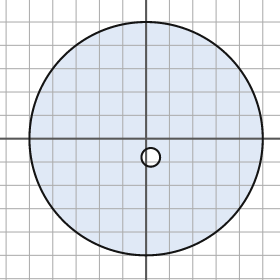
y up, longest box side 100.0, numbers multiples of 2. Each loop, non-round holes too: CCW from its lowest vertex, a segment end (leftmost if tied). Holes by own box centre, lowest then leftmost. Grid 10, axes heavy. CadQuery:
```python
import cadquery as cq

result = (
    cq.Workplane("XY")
    .moveTo(0.0, 0.0)
    .circle(50.0)
    .moveTo(2.0, -8.0)
    .circle(4.0)
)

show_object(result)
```